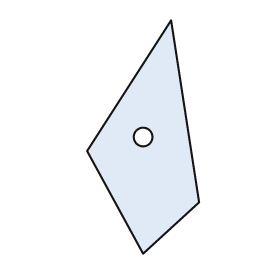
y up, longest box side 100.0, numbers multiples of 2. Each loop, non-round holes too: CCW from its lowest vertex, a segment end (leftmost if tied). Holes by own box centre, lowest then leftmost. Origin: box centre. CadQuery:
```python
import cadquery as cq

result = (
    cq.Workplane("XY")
    .moveTo(0.0, -50.0)
    .lineTo(24.0, -28.0)
    .lineTo(12.0, 50.0)
    .lineTo(-24.0, -6.0)
    .close()
    .moveTo(0.0, 0.0)
    .circle(4.0)
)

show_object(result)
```